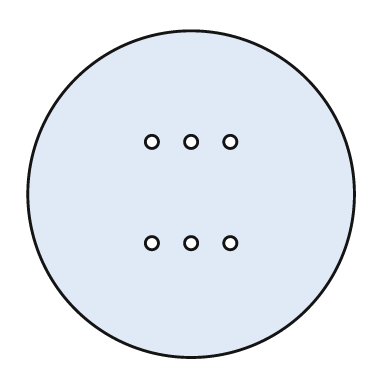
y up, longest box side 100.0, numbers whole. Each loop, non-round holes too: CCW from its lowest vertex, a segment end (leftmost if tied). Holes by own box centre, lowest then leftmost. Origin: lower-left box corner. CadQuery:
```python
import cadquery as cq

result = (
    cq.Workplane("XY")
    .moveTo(50.0, 50.0)
    .circle(50.0)
    .moveTo(38.0, 35.0)
    .circle(2.0)
    .moveTo(50.0, 35.0)
    .circle(2.0)
    .moveTo(62.0, 35.0)
    .circle(2.0)
    .moveTo(38.0, 66.0)
    .circle(2.0)
    .moveTo(50.0, 66.0)
    .circle(2.0)
    .moveTo(62.0, 66.0)
    .circle(2.0)
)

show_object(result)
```